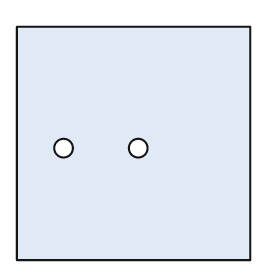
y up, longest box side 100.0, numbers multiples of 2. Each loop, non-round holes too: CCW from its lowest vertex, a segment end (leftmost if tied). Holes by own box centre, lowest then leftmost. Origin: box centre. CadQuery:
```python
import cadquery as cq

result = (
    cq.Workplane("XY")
    .moveTo(-50.0, -50.0)
    .lineTo(50.0, -50.0)
    .lineTo(50.0, 50.0)
    .lineTo(-50.0, 50.0)
    .close()
    .moveTo(-30.0, -2.0)
    .circle(4.0)
    .moveTo(2.0, -2.0)
    .circle(4.0)
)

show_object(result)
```